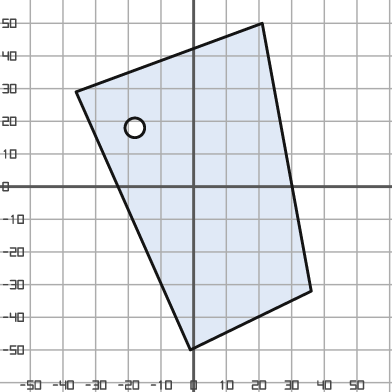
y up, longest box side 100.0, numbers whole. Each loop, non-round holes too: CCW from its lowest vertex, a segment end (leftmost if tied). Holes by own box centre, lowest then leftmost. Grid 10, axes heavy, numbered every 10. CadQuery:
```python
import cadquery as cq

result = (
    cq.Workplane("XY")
    .moveTo(-1.0, -50.0)
    .lineTo(36.0, -32.0)
    .lineTo(21.0, 50.0)
    .lineTo(-36.0, 29.0)
    .close()
    .moveTo(-18.0, 18.0)
    .circle(3.0)
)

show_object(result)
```